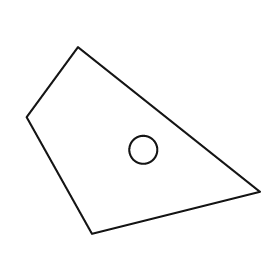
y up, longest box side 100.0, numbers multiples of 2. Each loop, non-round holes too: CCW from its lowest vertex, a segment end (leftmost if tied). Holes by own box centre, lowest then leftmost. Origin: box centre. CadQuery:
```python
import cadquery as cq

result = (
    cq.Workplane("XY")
    .moveTo(-22.0, -40.0)
    .lineTo(50.0, -22.0)
    .lineTo(-28.0, 40.0)
    .lineTo(-50.0, 10.0)
    .close()
    .moveTo(0.0, -4.0)
    .circle(6.0)
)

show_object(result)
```